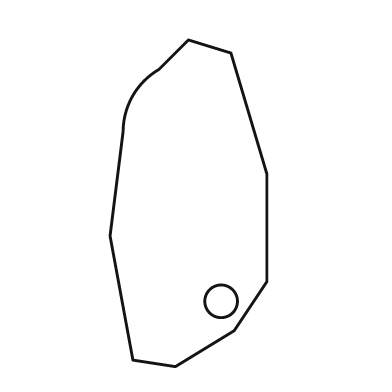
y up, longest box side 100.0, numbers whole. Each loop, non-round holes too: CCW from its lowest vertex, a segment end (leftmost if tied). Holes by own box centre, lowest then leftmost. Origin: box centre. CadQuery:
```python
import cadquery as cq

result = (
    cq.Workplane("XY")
    .moveTo(-4.0, -50.0)
    .lineTo(14.0, -39.0)
    .lineTo(24.0, -24.0)
    .lineTo(24.0, 9.0)
    .lineTo(13.0, 46.0)
    .lineTo(0.0, 50.0)
    .lineTo(-9.0, 41.0)
    .threePointArc((-17.0, 33.0), (-20.0, 22.0))
    .lineTo(-24.0, -10.0)
    .lineTo(-17.0, -48.0)
    .close()
    .moveTo(10.0, -30.0)
    .circle(5.0)
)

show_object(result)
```